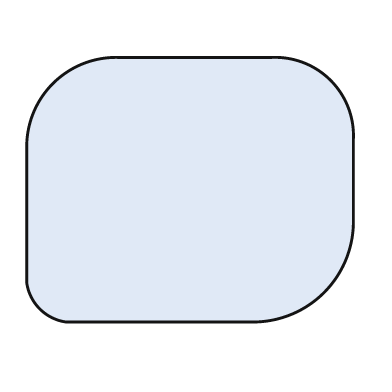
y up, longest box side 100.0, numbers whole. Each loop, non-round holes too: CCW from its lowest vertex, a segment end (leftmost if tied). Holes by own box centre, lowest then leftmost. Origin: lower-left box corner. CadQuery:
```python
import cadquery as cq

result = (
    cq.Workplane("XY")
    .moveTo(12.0, 0.0)
    .lineTo(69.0, 0.0)
    .threePointArc((91.0, 9.0), (100.0, 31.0))
    .lineTo(100.0, 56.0)
    .threePointArc((93.0, 74.0), (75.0, 81.0))
    .lineTo(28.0, 81.0)
    .threePointArc((8.0, 73.0), (0.0, 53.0))
    .lineTo(0.0, 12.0)
    .threePointArc((4.0, 4.0), (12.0, 0.0))
    .close()
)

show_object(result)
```